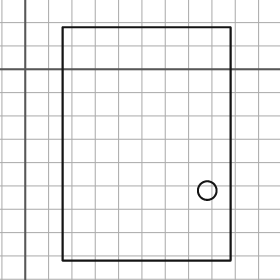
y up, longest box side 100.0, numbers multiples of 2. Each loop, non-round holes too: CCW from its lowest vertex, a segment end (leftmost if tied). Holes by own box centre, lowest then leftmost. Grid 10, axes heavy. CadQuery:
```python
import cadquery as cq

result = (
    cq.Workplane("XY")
    .moveTo(16.0, -82.0)
    .lineTo(88.0, -82.0)
    .lineTo(88.0, 18.0)
    .lineTo(16.0, 18.0)
    .close()
    .moveTo(78.0, -52.0)
    .circle(4.0)
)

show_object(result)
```